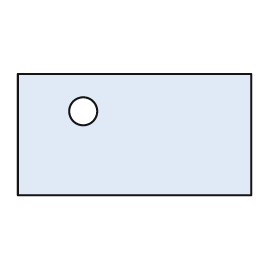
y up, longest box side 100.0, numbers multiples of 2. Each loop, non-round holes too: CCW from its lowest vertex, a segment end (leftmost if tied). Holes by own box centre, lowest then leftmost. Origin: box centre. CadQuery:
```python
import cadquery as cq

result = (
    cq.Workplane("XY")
    .moveTo(-50.0, -26.0)
    .lineTo(50.0, -26.0)
    .lineTo(50.0, 26.0)
    .lineTo(-50.0, 26.0)
    .close()
    .moveTo(-22.0, 10.0)
    .circle(6.0)
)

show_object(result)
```